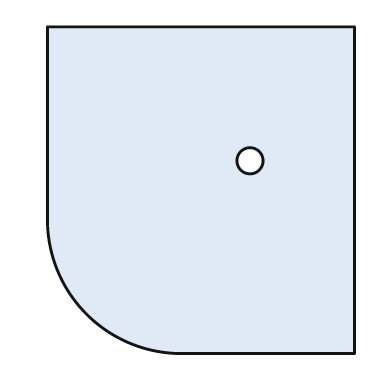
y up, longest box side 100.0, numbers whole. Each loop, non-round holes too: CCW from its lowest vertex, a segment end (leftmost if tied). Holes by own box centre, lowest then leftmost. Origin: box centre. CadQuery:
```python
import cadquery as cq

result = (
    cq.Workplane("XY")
    .moveTo(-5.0, -50.0)
    .lineTo(47.0, -50.0)
    .lineTo(47.0, 50.0)
    .lineTo(-47.0, 50.0)
    .lineTo(-47.0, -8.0)
    .threePointArc((-35.0, -38.0), (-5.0, -50.0))
    .close()
    .moveTo(15.0, 9.0)
    .circle(4.0)
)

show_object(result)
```